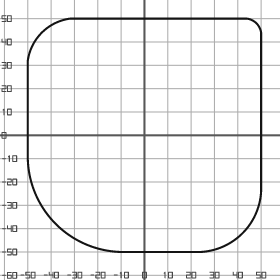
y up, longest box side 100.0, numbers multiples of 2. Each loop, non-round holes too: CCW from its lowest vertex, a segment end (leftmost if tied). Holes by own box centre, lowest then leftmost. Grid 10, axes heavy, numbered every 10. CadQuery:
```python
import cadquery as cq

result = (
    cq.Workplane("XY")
    .moveTo(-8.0, -50.0)
    .lineTo(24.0, -50.0)
    .threePointArc((42.0, -42.0), (50.0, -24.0))
    .lineTo(50.0, 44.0)
    .threePointArc((48.0, 48.0), (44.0, 50.0))
    .lineTo(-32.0, 50.0)
    .threePointArc((-44.0, 44.0), (-50.0, 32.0))
    .lineTo(-50.0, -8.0)
    .threePointArc((-38.0, -38.0), (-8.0, -50.0))
    .close()
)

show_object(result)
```